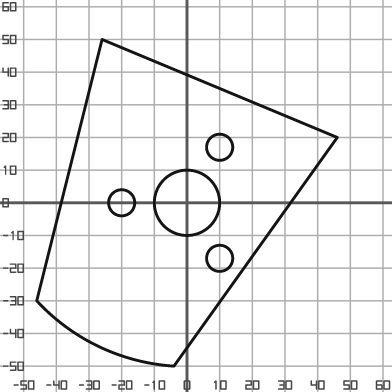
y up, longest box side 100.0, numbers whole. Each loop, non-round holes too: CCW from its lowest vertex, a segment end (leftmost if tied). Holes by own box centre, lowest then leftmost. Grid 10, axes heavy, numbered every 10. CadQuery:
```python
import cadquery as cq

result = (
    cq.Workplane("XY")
    .moveTo(-4.0, -50.0)
    .lineTo(46.0, 20.0)
    .lineTo(-26.0, 50.0)
    .lineTo(-46.0, -30.0)
    .threePointArc((-27.0, -44.0), (-4.0, -50.0))
    .close()
    .moveTo(10.0, -17.0)
    .circle(4.0)
    .moveTo(-20.0, 0.0)
    .circle(4.0)
    .moveTo(0.0, 0.0)
    .circle(10.0)
    .moveTo(10.0, 17.0)
    .circle(4.0)
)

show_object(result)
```